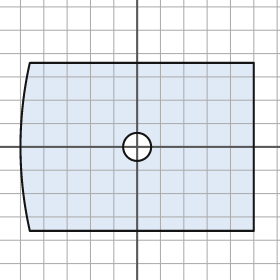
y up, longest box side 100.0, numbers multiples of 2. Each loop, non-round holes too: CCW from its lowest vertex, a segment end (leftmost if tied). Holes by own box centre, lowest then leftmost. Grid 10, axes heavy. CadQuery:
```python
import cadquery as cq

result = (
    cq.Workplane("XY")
    .moveTo(-46.0, -36.0)
    .lineTo(50.0, -36.0)
    .lineTo(50.0, 36.0)
    .lineTo(-46.0, 36.0)
    .threePointArc((-50.0, 0.0), (-46.0, -36.0))
    .close()
    .moveTo(0.0, 0.0)
    .circle(6.0)
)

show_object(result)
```